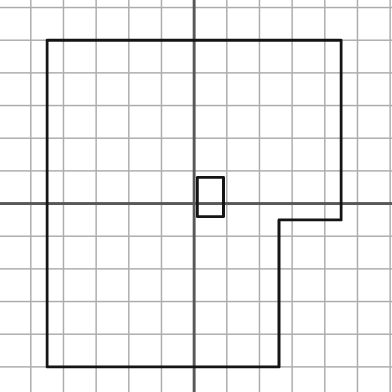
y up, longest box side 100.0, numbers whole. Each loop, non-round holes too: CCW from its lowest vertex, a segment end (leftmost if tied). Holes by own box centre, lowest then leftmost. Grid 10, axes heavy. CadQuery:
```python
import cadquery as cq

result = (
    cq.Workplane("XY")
    .moveTo(-45.0, -50.0)
    .lineTo(26.0, -50.0)
    .lineTo(26.0, -5.0)
    .lineTo(45.0, -5.0)
    .lineTo(45.0, 50.0)
    .lineTo(-45.0, 50.0)
    .close()
    .moveTo(1.0, -4.0)
    .lineTo(9.0, -4.0)
    .lineTo(9.0, 8.0)
    .lineTo(1.0, 8.0)
    .close()
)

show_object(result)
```